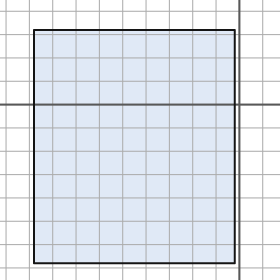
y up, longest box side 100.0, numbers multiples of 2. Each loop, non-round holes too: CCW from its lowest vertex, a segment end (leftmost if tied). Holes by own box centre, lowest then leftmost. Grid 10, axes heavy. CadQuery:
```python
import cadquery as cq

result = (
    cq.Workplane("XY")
    .moveTo(-88.0, -68.0)
    .lineTo(-2.0, -68.0)
    .lineTo(-2.0, 32.0)
    .lineTo(-88.0, 32.0)
    .close()
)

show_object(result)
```